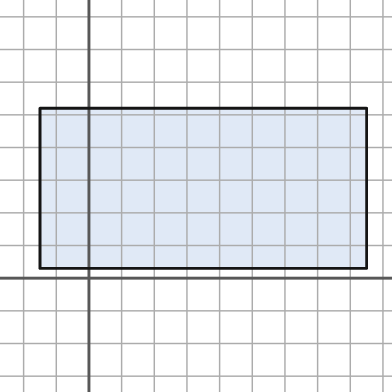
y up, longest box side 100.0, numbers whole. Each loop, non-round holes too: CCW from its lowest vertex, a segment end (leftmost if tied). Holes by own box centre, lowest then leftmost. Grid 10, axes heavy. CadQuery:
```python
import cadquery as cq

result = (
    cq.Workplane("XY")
    .moveTo(-15.0, 3.0)
    .lineTo(85.0, 3.0)
    .lineTo(85.0, 52.0)
    .lineTo(-15.0, 52.0)
    .close()
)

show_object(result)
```